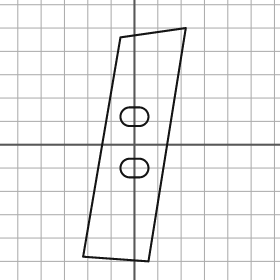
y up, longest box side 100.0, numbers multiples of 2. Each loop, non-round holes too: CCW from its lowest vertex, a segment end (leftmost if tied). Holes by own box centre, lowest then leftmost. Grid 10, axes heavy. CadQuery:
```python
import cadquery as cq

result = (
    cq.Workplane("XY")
    .moveTo(6.0, -50.0)
    .lineTo(22.0, 50.0)
    .lineTo(-6.0, 46.0)
    .lineTo(-22.0, -48.0)
    .close()
    .moveTo(-2.0, -14.0)
    .lineTo(2.0, -14.0)
    .threePointArc((6.0, -10.0), (2.0, -6.0))
    .lineTo(-2.0, -6.0)
    .threePointArc((-6.0, -10.0), (-2.0, -14.0))
    .close()
    .moveTo(-2.0, 8.0)
    .lineTo(2.0, 8.0)
    .threePointArc((6.0, 12.0), (2.0, 16.0))
    .lineTo(-2.0, 16.0)
    .threePointArc((-6.0, 12.0), (-2.0, 8.0))
    .close()
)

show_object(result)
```